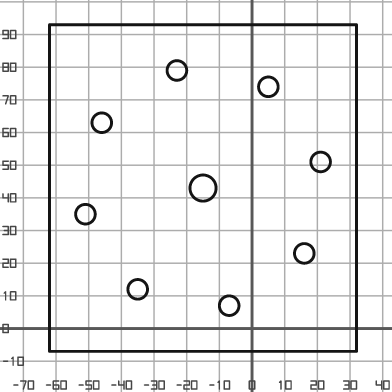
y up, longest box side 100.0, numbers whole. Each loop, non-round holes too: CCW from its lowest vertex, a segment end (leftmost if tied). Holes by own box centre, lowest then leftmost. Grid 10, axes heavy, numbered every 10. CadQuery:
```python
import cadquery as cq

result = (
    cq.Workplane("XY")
    .moveTo(-62.0, -7.0)
    .lineTo(32.0, -7.0)
    .lineTo(32.0, 93.0)
    .lineTo(-62.0, 93.0)
    .close()
    .moveTo(-7.0, 7.0)
    .circle(3.0)
    .moveTo(-35.0, 12.0)
    .circle(3.0)
    .moveTo(16.0, 23.0)
    .circle(3.0)
    .moveTo(-51.0, 35.0)
    .circle(3.0)
    .moveTo(-15.0, 43.0)
    .circle(4.0)
    .moveTo(21.0, 51.0)
    .circle(3.0)
    .moveTo(-46.0, 63.0)
    .circle(3.0)
    .moveTo(5.0, 74.0)
    .circle(3.0)
    .moveTo(-23.0, 79.0)
    .circle(3.0)
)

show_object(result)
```